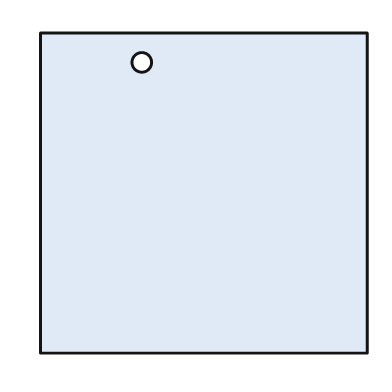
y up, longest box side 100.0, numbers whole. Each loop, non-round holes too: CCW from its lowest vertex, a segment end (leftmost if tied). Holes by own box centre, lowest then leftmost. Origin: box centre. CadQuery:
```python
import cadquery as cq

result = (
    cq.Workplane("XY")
    .moveTo(-50.0, -49.0)
    .lineTo(50.0, -49.0)
    .lineTo(50.0, 49.0)
    .lineTo(-50.0, 49.0)
    .close()
    .moveTo(-19.0, 40.0)
    .circle(3.0)
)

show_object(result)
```